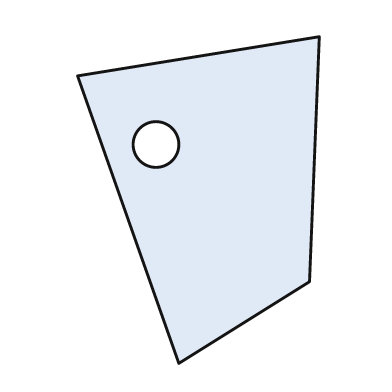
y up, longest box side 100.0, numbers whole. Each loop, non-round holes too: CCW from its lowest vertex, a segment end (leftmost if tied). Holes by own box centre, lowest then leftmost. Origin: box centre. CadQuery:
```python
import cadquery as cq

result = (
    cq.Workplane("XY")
    .moveTo(-6.0, -50.0)
    .lineTo(34.0, -25.0)
    .lineTo(37.0, 50.0)
    .lineTo(-37.0, 38.0)
    .close()
    .moveTo(-13.0, 17.0)
    .circle(7.0)
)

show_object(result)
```